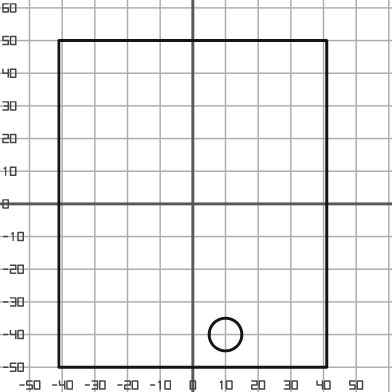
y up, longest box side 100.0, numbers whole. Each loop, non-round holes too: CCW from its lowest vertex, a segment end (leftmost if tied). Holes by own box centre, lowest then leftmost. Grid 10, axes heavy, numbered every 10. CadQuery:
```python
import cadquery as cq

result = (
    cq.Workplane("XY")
    .moveTo(-41.0, -50.0)
    .lineTo(41.0, -50.0)
    .lineTo(41.0, 50.0)
    .lineTo(-41.0, 50.0)
    .close()
    .moveTo(10.0, -40.0)
    .circle(5.0)
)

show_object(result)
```